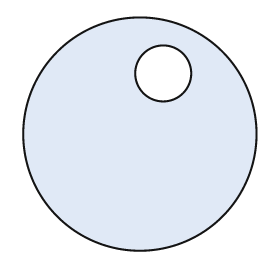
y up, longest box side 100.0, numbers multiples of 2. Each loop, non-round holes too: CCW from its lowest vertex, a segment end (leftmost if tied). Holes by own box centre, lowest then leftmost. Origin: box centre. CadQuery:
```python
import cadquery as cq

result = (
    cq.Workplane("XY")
    .moveTo(0.0, 0.0)
    .circle(50.0)
    .moveTo(10.0, 26.0)
    .circle(12.0)
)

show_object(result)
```